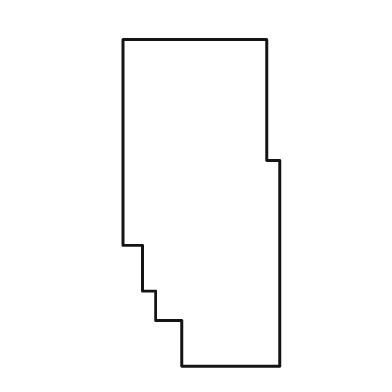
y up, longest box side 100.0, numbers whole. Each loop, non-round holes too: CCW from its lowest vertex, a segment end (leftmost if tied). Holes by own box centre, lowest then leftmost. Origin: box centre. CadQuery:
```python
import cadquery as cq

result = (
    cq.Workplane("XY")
    .moveTo(-6.0, -50.0)
    .lineTo(24.0, -50.0)
    .lineTo(24.0, 13.0)
    .lineTo(20.0, 13.0)
    .lineTo(20.0, 50.0)
    .lineTo(-24.0, 50.0)
    .lineTo(-24.0, -13.0)
    .lineTo(-18.0, -13.0)
    .lineTo(-18.0, -27.0)
    .lineTo(-14.0, -27.0)
    .lineTo(-14.0, -36.0)
    .lineTo(-6.0, -36.0)
    .close()
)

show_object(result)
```